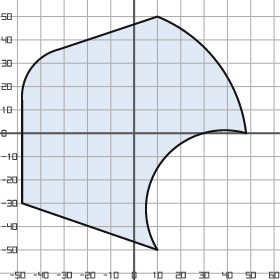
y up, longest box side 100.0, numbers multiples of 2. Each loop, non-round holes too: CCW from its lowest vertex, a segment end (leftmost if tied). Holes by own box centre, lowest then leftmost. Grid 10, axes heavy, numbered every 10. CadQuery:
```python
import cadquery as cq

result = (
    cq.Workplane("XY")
    .moveTo(10.0, -50.0)
    .threePointArc((12.0, -12.0), (48.0, 0.0))
    .threePointArc((36.0, 30.0), (10.0, 50.0))
    .lineTo(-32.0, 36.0)
    .threePointArc((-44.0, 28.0), (-48.0, 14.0))
    .lineTo(-48.0, -30.0)
    .close()
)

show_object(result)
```